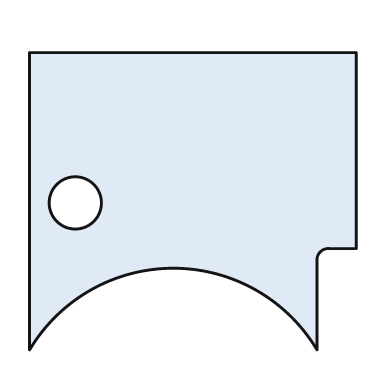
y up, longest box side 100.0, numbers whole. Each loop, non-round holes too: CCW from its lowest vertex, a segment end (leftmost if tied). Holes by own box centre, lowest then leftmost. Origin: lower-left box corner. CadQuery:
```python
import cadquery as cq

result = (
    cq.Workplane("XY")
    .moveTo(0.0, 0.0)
    .threePointArc((44.0, 25.0), (88.0, 0.0))
    .lineTo(88.0, 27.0)
    .threePointArc((89.0, 30.0), (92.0, 31.0))
    .lineTo(100.0, 31.0)
    .lineTo(100.0, 91.0)
    .lineTo(0.0, 91.0)
    .close()
    .moveTo(14.0, 45.0)
    .circle(8.0)
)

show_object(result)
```